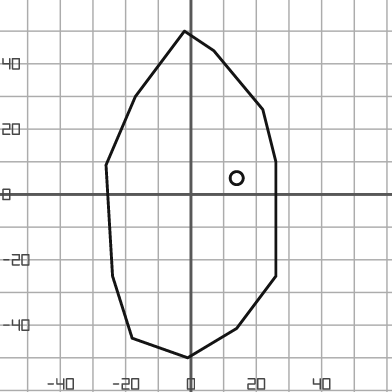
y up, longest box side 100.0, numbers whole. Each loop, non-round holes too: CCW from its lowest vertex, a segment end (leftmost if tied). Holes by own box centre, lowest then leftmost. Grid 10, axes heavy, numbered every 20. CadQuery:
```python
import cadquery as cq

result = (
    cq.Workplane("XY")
    .moveTo(-1.0, -50.0)
    .lineTo(14.0, -41.0)
    .lineTo(26.0, -25.0)
    .lineTo(26.0, 10.0)
    .lineTo(22.0, 26.0)
    .lineTo(7.0, 44.0)
    .lineTo(-2.0, 50.0)
    .lineTo(-17.0, 30.0)
    .lineTo(-26.0, 9.0)
    .lineTo(-24.0, -25.0)
    .lineTo(-18.0, -44.0)
    .close()
    .moveTo(14.0, 5.0)
    .circle(2.0)
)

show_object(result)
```